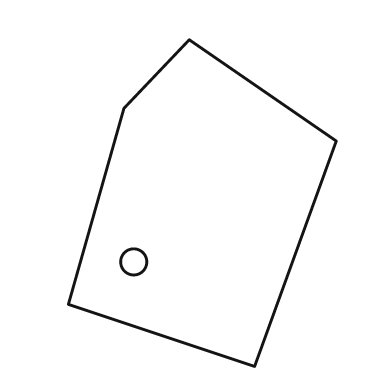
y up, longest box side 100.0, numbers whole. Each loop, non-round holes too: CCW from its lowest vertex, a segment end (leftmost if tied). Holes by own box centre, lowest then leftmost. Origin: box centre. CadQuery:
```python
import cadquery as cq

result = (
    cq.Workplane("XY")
    .moveTo(16.0, -50.0)
    .lineTo(41.0, 19.0)
    .lineTo(-4.0, 50.0)
    .lineTo(-24.0, 29.0)
    .lineTo(-41.0, -31.0)
    .close()
    .moveTo(-21.0, -18.0)
    .circle(4.0)
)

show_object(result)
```